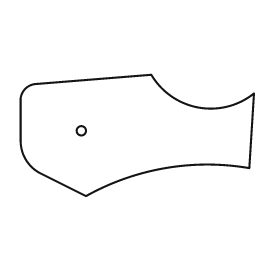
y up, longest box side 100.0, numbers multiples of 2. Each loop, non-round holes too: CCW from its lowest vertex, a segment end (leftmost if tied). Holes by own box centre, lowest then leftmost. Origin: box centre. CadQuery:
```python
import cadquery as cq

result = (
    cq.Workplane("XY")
    .moveTo(-22.0, -26.0)
    .threePointArc((12.0, -14.0), (48.0, -14.0))
    .lineTo(50.0, 18.0)
    .threePointArc((26.0, 12.0), (6.0, 26.0))
    .lineTo(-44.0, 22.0)
    .threePointArc((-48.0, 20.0), (-50.0, 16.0))
    .lineTo(-50.0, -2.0)
    .threePointArc((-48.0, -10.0), (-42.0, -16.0))
    .close()
    .moveTo(-24.0, 2.0)
    .circle(2.0)
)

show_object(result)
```